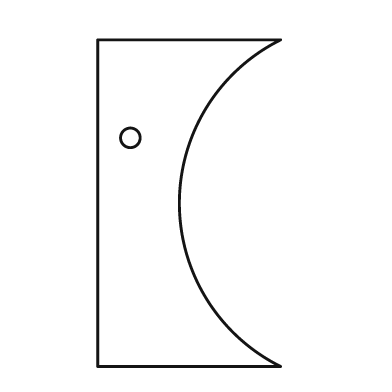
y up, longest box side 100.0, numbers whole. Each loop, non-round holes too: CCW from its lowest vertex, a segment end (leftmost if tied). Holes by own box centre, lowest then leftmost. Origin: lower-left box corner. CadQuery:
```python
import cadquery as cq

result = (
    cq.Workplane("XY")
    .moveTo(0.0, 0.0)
    .lineTo(56.0, 0.0)
    .threePointArc((25.0, 50.0), (56.0, 100.0))
    .lineTo(0.0, 100.0)
    .close()
    .moveTo(10.0, 70.0)
    .circle(3.0)
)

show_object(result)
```